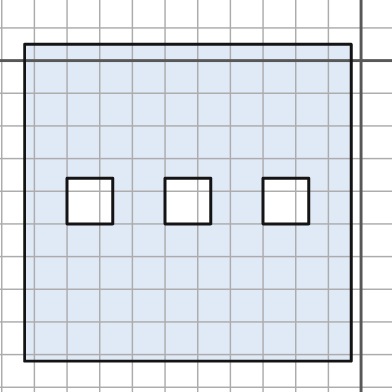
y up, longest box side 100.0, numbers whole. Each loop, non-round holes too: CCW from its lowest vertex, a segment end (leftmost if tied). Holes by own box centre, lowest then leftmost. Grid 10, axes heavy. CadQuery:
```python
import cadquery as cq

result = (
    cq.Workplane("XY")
    .moveTo(-103.0, -92.0)
    .lineTo(-3.0, -92.0)
    .lineTo(-3.0, 5.0)
    .lineTo(-103.0, 5.0)
    .close()
    .moveTo(-90.0, -50.0)
    .lineTo(-76.0, -50.0)
    .lineTo(-76.0, -36.0)
    .lineTo(-90.0, -36.0)
    .close()
    .moveTo(-60.0, -50.0)
    .lineTo(-46.0, -50.0)
    .lineTo(-46.0, -36.0)
    .lineTo(-60.0, -36.0)
    .close()
    .moveTo(-30.0, -50.0)
    .lineTo(-16.0, -50.0)
    .lineTo(-16.0, -36.0)
    .lineTo(-30.0, -36.0)
    .close()
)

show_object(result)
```